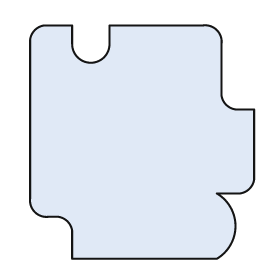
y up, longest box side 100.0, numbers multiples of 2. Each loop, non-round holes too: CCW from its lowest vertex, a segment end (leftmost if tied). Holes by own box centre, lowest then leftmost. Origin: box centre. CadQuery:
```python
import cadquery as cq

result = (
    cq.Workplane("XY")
    .moveTo(-30.0, -50.0)
    .lineTo(32.0, -50.0)
    .threePointArc((40.0, -36.0), (32.0, -22.0))
    .lineTo(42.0, -22.0)
    .threePointArc((46.0, -20.0), (48.0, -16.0))
    .lineTo(48.0, 14.0)
    .lineTo(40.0, 14.0)
    .threePointArc((36.0, 16.0), (34.0, 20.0))
    .lineTo(34.0, 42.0)
    .threePointArc((32.0, 48.0), (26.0, 50.0))
    .lineTo(-14.0, 50.0)
    .lineTo(-14.0, 42.0)
    .threePointArc((-22.0, 34.0), (-30.0, 42.0))
    .lineTo(-30.0, 50.0)
    .lineTo(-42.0, 50.0)
    .threePointArc((-46.0, 48.0), (-48.0, 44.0))
    .lineTo(-48.0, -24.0)
    .threePointArc((-46.0, -30.0), (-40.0, -32.0))
    .lineTo(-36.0, -32.0)
    .threePointArc((-32.0, -34.0), (-30.0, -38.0))
    .close()
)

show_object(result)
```